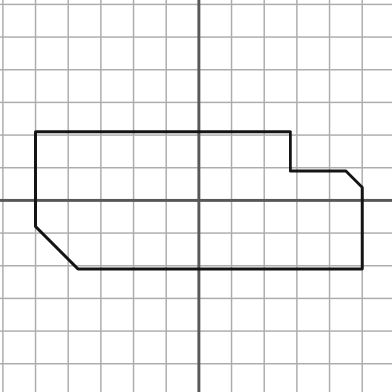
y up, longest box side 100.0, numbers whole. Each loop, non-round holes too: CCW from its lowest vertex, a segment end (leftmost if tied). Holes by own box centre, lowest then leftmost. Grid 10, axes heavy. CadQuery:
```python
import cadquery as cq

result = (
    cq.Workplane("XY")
    .moveTo(-37.0, -21.0)
    .lineTo(50.0, -21.0)
    .lineTo(50.0, 4.0)
    .lineTo(45.0, 9.0)
    .lineTo(28.0, 9.0)
    .lineTo(28.0, 21.0)
    .lineTo(-50.0, 21.0)
    .lineTo(-50.0, -8.0)
    .close()
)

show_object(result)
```